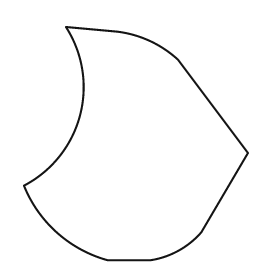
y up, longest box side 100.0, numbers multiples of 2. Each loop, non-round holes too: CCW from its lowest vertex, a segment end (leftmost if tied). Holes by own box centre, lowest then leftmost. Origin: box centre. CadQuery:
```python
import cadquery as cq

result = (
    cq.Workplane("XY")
    .moveTo(-12.0, -50.0)
    .lineTo(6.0, -50.0)
    .threePointArc((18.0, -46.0), (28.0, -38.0))
    .lineTo(48.0, -4.0)
    .lineTo(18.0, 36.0)
    .threePointArc((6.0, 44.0), (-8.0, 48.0))
    .lineTo(-30.0, 50.0)
    .threePointArc((-24.0, 12.0), (-48.0, -18.0))
    .threePointArc((-34.0, -38.0), (-12.0, -50.0))
    .close()
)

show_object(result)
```